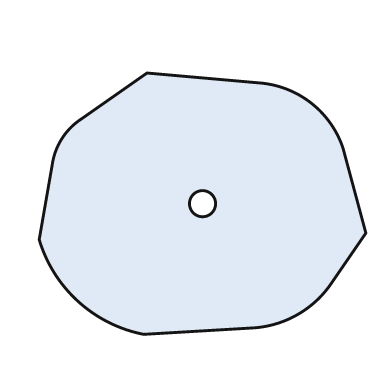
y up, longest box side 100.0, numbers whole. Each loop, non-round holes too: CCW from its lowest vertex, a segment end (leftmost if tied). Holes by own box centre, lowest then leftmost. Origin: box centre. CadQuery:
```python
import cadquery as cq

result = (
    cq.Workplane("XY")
    .moveTo(-18.0, -40.0)
    .lineTo(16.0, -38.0)
    .threePointArc((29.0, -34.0), (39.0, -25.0))
    .lineTo(50.0, -9.0)
    .lineTo(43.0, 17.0)
    .threePointArc((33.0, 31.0), (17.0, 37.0))
    .lineTo(-17.0, 40.0)
    .lineTo(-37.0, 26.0)
    .threePointArc((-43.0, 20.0), (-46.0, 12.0))
    .lineTo(-50.0, -11.0)
    .threePointArc((-38.0, -30.0), (-18.0, -40.0))
    .close()
    .moveTo(0.0, 0.0)
    .circle(4.0)
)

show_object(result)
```